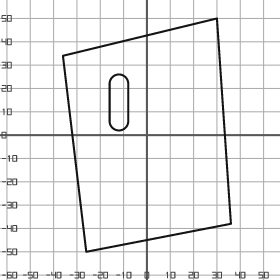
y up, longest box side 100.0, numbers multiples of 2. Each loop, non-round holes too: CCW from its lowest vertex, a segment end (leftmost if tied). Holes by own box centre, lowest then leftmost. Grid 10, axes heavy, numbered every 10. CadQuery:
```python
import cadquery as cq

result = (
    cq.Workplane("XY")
    .moveTo(-26.0, -50.0)
    .lineTo(36.0, -38.0)
    .lineTo(30.0, 50.0)
    .lineTo(-36.0, 34.0)
    .close()
    .moveTo(-16.0, 6.0)
    .threePointArc((-12.0, 2.0), (-8.0, 6.0))
    .lineTo(-8.0, 22.0)
    .threePointArc((-12.0, 26.0), (-16.0, 22.0))
    .close()
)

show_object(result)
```